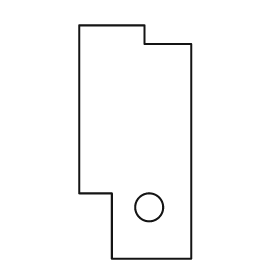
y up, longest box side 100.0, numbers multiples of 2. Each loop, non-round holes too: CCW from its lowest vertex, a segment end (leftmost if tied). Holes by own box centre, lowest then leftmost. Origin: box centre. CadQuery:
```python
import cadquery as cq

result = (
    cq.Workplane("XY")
    .moveTo(-10.0, -50.0)
    .lineTo(24.0, -50.0)
    .lineTo(24.0, 42.0)
    .lineTo(4.0, 42.0)
    .lineTo(4.0, 50.0)
    .lineTo(-24.0, 50.0)
    .lineTo(-24.0, -22.0)
    .lineTo(-10.0, -22.0)
    .close()
    .moveTo(6.0, -28.0)
    .circle(6.0)
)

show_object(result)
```